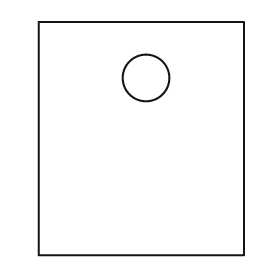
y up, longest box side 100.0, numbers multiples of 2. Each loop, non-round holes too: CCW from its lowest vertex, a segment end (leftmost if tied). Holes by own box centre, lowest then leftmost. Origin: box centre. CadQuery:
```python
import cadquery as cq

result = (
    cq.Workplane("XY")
    .moveTo(-44.0, -50.0)
    .lineTo(44.0, -50.0)
    .lineTo(44.0, 50.0)
    .lineTo(-44.0, 50.0)
    .close()
    .moveTo(2.0, 26.0)
    .circle(10.0)
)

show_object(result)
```